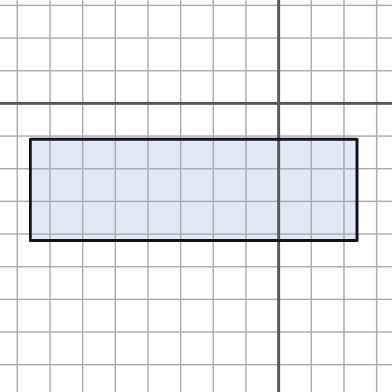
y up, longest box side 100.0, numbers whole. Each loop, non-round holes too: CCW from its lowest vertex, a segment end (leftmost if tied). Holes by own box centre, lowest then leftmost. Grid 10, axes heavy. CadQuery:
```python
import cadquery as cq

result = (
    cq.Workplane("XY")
    .moveTo(-76.0, -42.0)
    .lineTo(24.0, -42.0)
    .lineTo(24.0, -11.0)
    .lineTo(-76.0, -11.0)
    .close()
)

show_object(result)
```